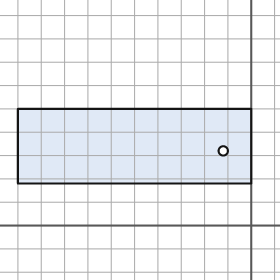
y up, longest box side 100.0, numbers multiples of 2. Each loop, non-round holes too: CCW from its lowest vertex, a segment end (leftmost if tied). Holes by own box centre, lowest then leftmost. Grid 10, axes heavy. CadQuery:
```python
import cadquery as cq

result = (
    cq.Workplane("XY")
    .moveTo(-100.0, 18.0)
    .lineTo(0.0, 18.0)
    .lineTo(0.0, 50.0)
    .lineTo(-100.0, 50.0)
    .close()
    .moveTo(-12.0, 32.0)
    .circle(2.0)
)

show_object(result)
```